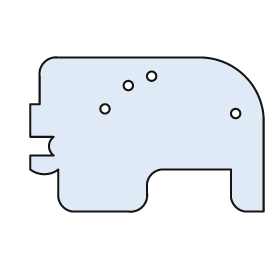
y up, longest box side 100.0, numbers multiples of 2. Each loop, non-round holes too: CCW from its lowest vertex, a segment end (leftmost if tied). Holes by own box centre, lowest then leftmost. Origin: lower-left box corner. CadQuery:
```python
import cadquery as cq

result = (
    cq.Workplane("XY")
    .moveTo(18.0, 0.0)
    .lineTo(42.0, 0.0)
    .threePointArc((48.0, 2.0), (50.0, 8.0))
    .lineTo(50.0, 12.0)
    .threePointArc((52.0, 16.0), (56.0, 18.0))
    .lineTo(86.0, 18.0)
    .lineTo(86.0, 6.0)
    .threePointArc((88.0, 2.0), (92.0, 0.0))
    .lineTo(100.0, 0.0)
    .lineTo(100.0, 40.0)
    .threePointArc((92.0, 58.0), (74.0, 66.0))
    .lineTo(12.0, 66.0)
    .threePointArc((6.0, 64.0), (4.0, 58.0))
    .lineTo(4.0, 46.0)
    .lineTo(0.0, 46.0)
    .lineTo(0.0, 32.0)
    .lineTo(10.0, 32.0)
    .threePointArc((8.0, 28.0), (10.0, 24.0))
    .lineTo(0.0, 24.0)
    .lineTo(0.0, 18.0)
    .threePointArc((6.0, 16.0), (12.0, 18.0))
    .lineTo(12.0, 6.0)
    .threePointArc((14.0, 2.0), (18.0, 0.0))
    .close()
    .moveTo(88.0, 42.0)
    .circle(2.0)
    .moveTo(32.0, 44.0)
    .circle(2.0)
    .moveTo(42.0, 54.0)
    .circle(2.0)
    .moveTo(52.0, 58.0)
    .circle(2.0)
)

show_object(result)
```